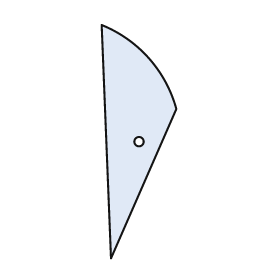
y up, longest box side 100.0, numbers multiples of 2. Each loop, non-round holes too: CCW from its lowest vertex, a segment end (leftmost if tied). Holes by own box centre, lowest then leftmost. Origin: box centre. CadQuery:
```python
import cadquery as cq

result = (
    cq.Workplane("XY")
    .moveTo(-12.0, -50.0)
    .lineTo(16.0, 14.0)
    .threePointArc((4.0, 36.0), (-16.0, 50.0))
    .close()
    .moveTo(0.0, 0.0)
    .circle(2.0)
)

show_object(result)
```